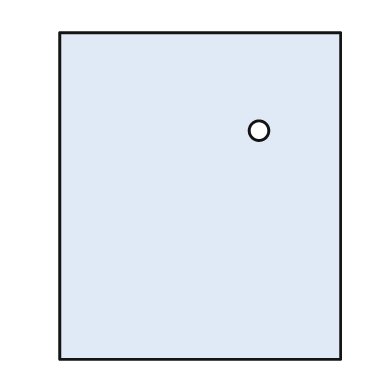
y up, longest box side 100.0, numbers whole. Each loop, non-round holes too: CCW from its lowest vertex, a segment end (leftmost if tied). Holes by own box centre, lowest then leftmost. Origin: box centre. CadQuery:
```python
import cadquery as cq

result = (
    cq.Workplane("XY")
    .moveTo(-43.0, -50.0)
    .lineTo(43.0, -50.0)
    .lineTo(43.0, 50.0)
    .lineTo(-43.0, 50.0)
    .close()
    .moveTo(18.0, 20.0)
    .circle(3.0)
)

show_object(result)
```